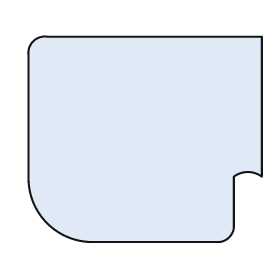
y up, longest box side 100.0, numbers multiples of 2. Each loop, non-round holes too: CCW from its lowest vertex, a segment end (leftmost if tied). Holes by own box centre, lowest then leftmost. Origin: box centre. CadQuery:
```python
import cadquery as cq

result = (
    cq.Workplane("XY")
    .moveTo(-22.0, -44.0)
    .lineTo(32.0, -44.0)
    .threePointArc((36.0, -42.0), (38.0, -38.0))
    .lineTo(38.0, -16.0)
    .threePointArc((44.0, -14.0), (50.0, -16.0))
    .lineTo(50.0, 44.0)
    .lineTo(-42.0, 44.0)
    .threePointArc((-48.0, 42.0), (-50.0, 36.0))
    .lineTo(-50.0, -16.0)
    .threePointArc((-42.0, -36.0), (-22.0, -44.0))
    .close()
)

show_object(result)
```